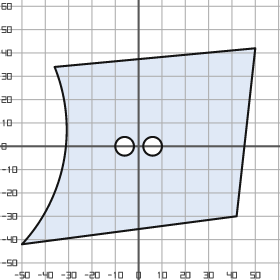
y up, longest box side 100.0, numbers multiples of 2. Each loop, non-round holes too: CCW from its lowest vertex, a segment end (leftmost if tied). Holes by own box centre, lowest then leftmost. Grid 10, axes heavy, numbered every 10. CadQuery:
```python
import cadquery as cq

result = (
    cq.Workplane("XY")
    .moveTo(-50.0, -42.0)
    .lineTo(42.0, -30.0)
    .lineTo(50.0, 42.0)
    .lineTo(-36.0, 34.0)
    .threePointArc((-32.0, -6.0), (-50.0, -42.0))
    .close()
    .moveTo(-6.0, 0.0)
    .circle(4.0)
    .moveTo(6.0, 0.0)
    .circle(4.0)
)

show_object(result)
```